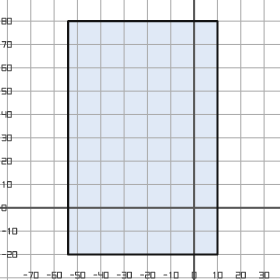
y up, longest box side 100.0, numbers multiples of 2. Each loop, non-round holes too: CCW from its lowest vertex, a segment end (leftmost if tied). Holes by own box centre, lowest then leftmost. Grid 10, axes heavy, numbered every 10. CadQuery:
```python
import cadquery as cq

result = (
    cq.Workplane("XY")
    .moveTo(-54.0, -20.0)
    .lineTo(10.0, -20.0)
    .lineTo(10.0, 80.0)
    .lineTo(-54.0, 80.0)
    .close()
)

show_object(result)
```